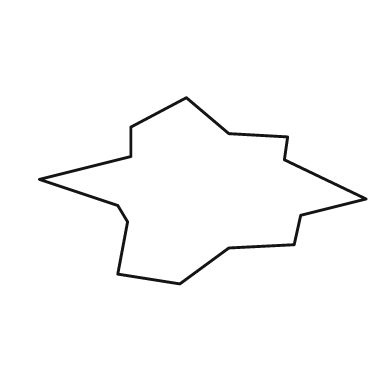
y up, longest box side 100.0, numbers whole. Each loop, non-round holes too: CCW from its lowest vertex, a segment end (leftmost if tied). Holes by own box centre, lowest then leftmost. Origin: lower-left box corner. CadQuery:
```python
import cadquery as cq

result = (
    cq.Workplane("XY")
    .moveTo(43.0, 0.0)
    .lineTo(58.0, 11.0)
    .lineTo(78.0, 12.0)
    .lineTo(80.0, 21.0)
    .lineTo(100.0, 26.0)
    .lineTo(75.0, 38.0)
    .lineTo(76.0, 45.0)
    .lineTo(58.0, 46.0)
    .lineTo(45.0, 57.0)
    .lineTo(28.0, 48.0)
    .lineTo(28.0, 39.0)
    .lineTo(0.0, 32.0)
    .lineTo(24.0, 24.0)
    .lineTo(27.0, 19.0)
    .lineTo(24.0, 3.0)
    .close()
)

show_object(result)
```